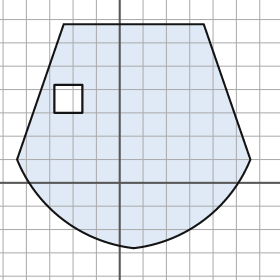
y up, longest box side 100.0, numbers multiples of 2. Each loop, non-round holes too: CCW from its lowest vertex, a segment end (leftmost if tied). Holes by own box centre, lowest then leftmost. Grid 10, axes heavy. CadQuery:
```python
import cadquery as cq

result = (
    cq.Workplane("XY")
    .moveTo(6.0, -28.0)
    .threePointArc((36.0, -16.0), (56.0, 10.0))
    .lineTo(36.0, 68.0)
    .lineTo(-24.0, 68.0)
    .lineTo(-44.0, 10.0)
    .threePointArc((-24.0, -16.0), (6.0, -28.0))
    .close()
    .moveTo(-28.0, 30.0)
    .lineTo(-16.0, 30.0)
    .lineTo(-16.0, 42.0)
    .lineTo(-28.0, 42.0)
    .close()
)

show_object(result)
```